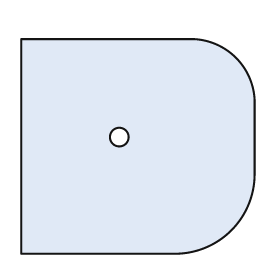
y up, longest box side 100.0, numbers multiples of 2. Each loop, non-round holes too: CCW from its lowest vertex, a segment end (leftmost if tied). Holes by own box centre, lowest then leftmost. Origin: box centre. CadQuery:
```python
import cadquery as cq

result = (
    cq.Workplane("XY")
    .moveTo(-50.0, -46.0)
    .lineTo(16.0, -46.0)
    .threePointArc((40.0, -36.0), (50.0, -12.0))
    .lineTo(50.0, 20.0)
    .threePointArc((42.0, 38.0), (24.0, 46.0))
    .lineTo(-50.0, 46.0)
    .close()
    .moveTo(-8.0, 4.0)
    .circle(4.0)
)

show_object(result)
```